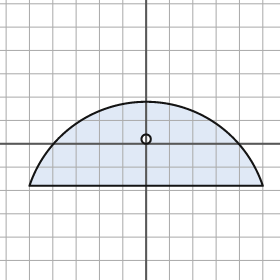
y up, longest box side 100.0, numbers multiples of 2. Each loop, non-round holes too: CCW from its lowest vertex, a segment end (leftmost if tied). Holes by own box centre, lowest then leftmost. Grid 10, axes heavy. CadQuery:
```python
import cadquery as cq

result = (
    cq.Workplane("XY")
    .moveTo(-50.0, -18.0)
    .lineTo(50.0, -18.0)
    .threePointArc((0.0, 18.0), (-50.0, -18.0))
    .close()
    .moveTo(0.0, 2.0)
    .circle(2.0)
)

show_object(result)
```